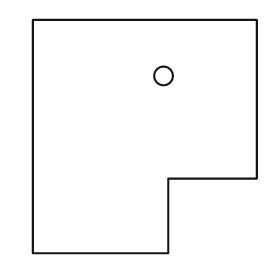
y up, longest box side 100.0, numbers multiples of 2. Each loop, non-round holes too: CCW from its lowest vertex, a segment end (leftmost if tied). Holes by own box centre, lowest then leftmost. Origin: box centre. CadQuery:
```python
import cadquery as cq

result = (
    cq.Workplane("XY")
    .moveTo(-48.0, -50.0)
    .lineTo(10.0, -50.0)
    .lineTo(10.0, -18.0)
    .lineTo(48.0, -18.0)
    .lineTo(48.0, 50.0)
    .lineTo(-48.0, 50.0)
    .close()
    .moveTo(8.0, 26.0)
    .circle(4.0)
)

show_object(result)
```